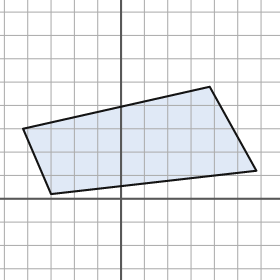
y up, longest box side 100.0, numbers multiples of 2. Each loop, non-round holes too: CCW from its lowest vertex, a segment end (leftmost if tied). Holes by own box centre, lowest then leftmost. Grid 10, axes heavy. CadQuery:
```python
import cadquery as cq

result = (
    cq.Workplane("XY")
    .moveTo(-30.0, 2.0)
    .lineTo(58.0, 12.0)
    .lineTo(38.0, 48.0)
    .lineTo(-42.0, 30.0)
    .close()
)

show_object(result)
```